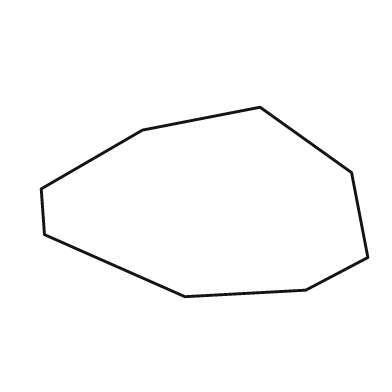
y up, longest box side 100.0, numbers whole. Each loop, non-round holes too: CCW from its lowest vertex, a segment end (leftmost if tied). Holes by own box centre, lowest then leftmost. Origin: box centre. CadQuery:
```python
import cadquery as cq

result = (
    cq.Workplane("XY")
    .moveTo(-6.0, -29.0)
    .lineTo(31.0, -27.0)
    .lineTo(50.0, -17.0)
    .lineTo(45.0, 9.0)
    .lineTo(17.0, 29.0)
    .lineTo(-19.0, 22.0)
    .lineTo(-50.0, 4.0)
    .lineTo(-49.0, -10.0)
    .close()
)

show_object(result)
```